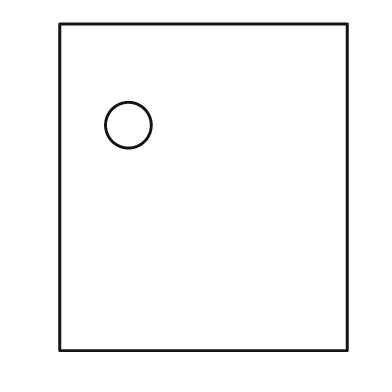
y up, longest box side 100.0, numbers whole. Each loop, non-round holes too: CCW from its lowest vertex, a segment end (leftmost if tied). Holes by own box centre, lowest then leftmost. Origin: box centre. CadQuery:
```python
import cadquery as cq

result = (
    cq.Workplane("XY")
    .moveTo(-44.0, -50.0)
    .lineTo(44.0, -50.0)
    .lineTo(44.0, 50.0)
    .lineTo(-44.0, 50.0)
    .close()
    .moveTo(-23.0, 19.0)
    .circle(7.0)
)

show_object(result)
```